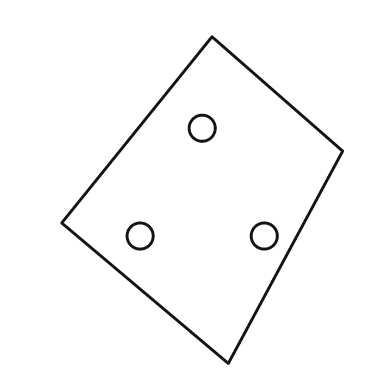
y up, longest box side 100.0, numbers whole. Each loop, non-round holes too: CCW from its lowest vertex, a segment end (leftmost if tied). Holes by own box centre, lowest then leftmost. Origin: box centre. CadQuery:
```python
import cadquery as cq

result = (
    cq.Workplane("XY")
    .moveTo(8.0, -50.0)
    .lineTo(43.0, 15.0)
    .lineTo(3.0, 50.0)
    .lineTo(-43.0, -7.0)
    .close()
    .moveTo(-19.0, -11.0)
    .circle(4.0)
    .moveTo(19.0, -11.0)
    .circle(4.0)
    .moveTo(0.0, 22.0)
    .circle(4.0)
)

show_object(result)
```